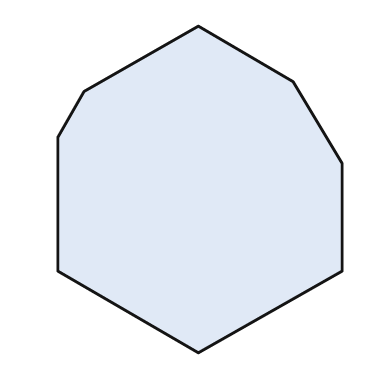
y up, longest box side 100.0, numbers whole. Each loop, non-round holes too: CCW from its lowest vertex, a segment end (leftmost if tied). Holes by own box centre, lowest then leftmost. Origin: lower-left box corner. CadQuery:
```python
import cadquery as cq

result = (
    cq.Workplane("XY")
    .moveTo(43.0, 0.0)
    .lineTo(87.0, 25.0)
    .lineTo(87.0, 58.0)
    .lineTo(72.0, 83.0)
    .lineTo(43.0, 100.0)
    .lineTo(8.0, 80.0)
    .lineTo(0.0, 66.0)
    .lineTo(0.0, 25.0)
    .close()
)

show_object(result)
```